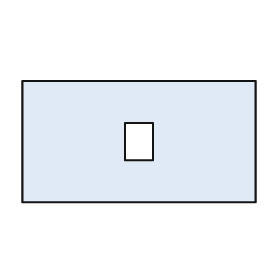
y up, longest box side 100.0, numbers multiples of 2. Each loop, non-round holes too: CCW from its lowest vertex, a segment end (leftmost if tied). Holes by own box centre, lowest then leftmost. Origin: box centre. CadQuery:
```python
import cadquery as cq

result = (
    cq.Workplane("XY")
    .moveTo(-50.0, -26.0)
    .lineTo(50.0, -26.0)
    .lineTo(50.0, 26.0)
    .lineTo(-50.0, 26.0)
    .close()
    .moveTo(-6.0, -8.0)
    .lineTo(6.0, -8.0)
    .lineTo(6.0, 8.0)
    .lineTo(-6.0, 8.0)
    .close()
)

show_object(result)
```